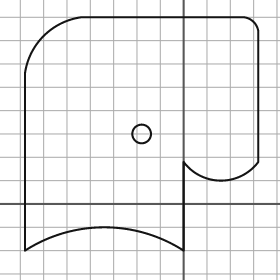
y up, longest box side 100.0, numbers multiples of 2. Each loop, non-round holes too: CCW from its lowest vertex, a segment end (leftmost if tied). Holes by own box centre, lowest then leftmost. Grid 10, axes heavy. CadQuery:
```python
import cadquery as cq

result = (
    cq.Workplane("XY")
    .moveTo(-68.0, -20.0)
    .threePointArc((-34.0, -10.0), (0.0, -20.0))
    .lineTo(0.0, 18.0)
    .threePointArc((16.0, 10.0), (32.0, 18.0))
    .lineTo(32.0, 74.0)
    .threePointArc((30.0, 78.0), (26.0, 80.0))
    .lineTo(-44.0, 80.0)
    .threePointArc((-60.0, 72.0), (-68.0, 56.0))
    .close()
    .moveTo(-18.0, 30.0)
    .circle(4.0)
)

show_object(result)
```